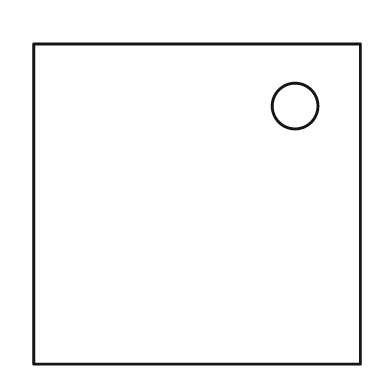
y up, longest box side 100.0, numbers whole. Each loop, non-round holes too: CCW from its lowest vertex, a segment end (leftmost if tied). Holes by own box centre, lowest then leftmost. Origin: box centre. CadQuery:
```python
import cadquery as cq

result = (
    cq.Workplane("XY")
    .moveTo(-50.0, -49.0)
    .lineTo(50.0, -49.0)
    .lineTo(50.0, 49.0)
    .lineTo(-50.0, 49.0)
    .close()
    .moveTo(30.0, 30.0)
    .circle(7.0)
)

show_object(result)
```